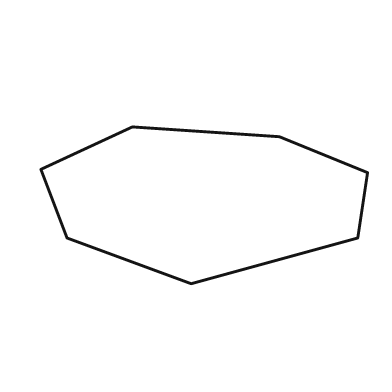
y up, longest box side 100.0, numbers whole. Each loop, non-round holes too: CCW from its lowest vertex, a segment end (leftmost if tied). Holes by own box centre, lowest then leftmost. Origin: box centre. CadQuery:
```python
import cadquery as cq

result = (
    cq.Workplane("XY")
    .moveTo(-4.0, -24.0)
    .lineTo(47.0, -10.0)
    .lineTo(50.0, 10.0)
    .lineTo(23.0, 21.0)
    .lineTo(-22.0, 24.0)
    .lineTo(-50.0, 11.0)
    .lineTo(-42.0, -10.0)
    .close()
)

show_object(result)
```